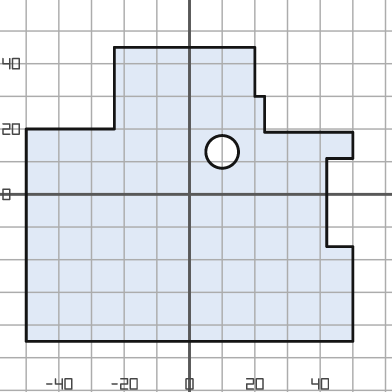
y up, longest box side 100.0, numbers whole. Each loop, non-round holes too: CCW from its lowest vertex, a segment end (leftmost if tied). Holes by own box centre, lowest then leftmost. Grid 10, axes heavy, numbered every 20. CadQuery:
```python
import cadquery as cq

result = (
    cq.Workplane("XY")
    .moveTo(-50.0, -45.0)
    .lineTo(50.0, -45.0)
    .lineTo(50.0, -16.0)
    .lineTo(42.0, -16.0)
    .lineTo(42.0, 11.0)
    .lineTo(50.0, 11.0)
    .lineTo(50.0, 19.0)
    .lineTo(23.0, 19.0)
    .lineTo(23.0, 30.0)
    .lineTo(20.0, 30.0)
    .lineTo(20.0, 45.0)
    .lineTo(-23.0, 45.0)
    .lineTo(-23.0, 20.0)
    .lineTo(-50.0, 20.0)
    .close()
    .moveTo(10.0, 13.0)
    .circle(5.0)
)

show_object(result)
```